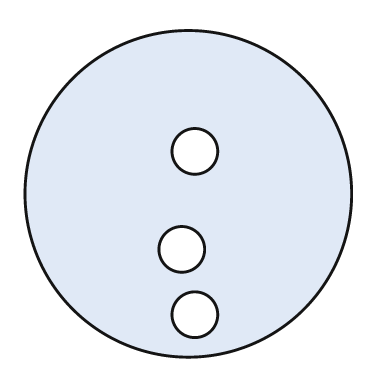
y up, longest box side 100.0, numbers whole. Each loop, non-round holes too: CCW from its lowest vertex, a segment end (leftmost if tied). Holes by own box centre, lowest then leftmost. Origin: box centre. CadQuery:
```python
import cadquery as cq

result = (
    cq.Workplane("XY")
    .moveTo(0.0, 0.0)
    .circle(50.0)
    .moveTo(2.0, -37.0)
    .circle(7.0)
    .moveTo(-2.0, -17.0)
    .circle(7.0)
    .moveTo(2.0, 13.0)
    .circle(7.0)
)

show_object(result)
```